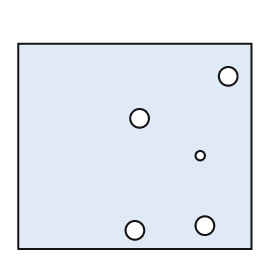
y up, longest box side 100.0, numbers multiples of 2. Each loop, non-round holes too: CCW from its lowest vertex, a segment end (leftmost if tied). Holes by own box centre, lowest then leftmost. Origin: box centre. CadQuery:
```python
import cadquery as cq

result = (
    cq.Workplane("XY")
    .moveTo(-50.0, -44.0)
    .lineTo(50.0, -44.0)
    .lineTo(50.0, 44.0)
    .lineTo(-50.0, 44.0)
    .close()
    .moveTo(0.0, -36.0)
    .circle(4.0)
    .moveTo(30.0, -34.0)
    .circle(4.0)
    .moveTo(28.0, -4.0)
    .circle(2.0)
    .moveTo(2.0, 12.0)
    .circle(4.0)
    .moveTo(40.0, 30.0)
    .circle(4.0)
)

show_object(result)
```